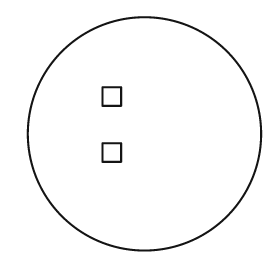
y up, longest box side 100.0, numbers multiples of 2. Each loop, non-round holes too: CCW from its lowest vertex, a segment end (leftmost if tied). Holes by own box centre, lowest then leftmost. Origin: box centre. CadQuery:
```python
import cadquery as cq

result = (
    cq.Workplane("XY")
    .moveTo(0.0, 0.0)
    .circle(50.0)
    .moveTo(-18.0, -12.0)
    .lineTo(-10.0, -12.0)
    .lineTo(-10.0, -4.0)
    .lineTo(-18.0, -4.0)
    .close()
    .moveTo(-18.0, 12.0)
    .lineTo(-10.0, 12.0)
    .lineTo(-10.0, 20.0)
    .lineTo(-18.0, 20.0)
    .close()
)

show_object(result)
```